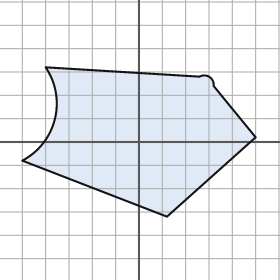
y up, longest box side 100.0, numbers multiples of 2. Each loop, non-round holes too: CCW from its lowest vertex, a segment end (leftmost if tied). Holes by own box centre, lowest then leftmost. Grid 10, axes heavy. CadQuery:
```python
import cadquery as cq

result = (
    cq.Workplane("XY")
    .moveTo(12.0, -32.0)
    .lineTo(50.0, 2.0)
    .lineTo(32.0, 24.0)
    .threePointArc((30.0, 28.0), (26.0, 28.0))
    .lineTo(-40.0, 32.0)
    .threePointArc((-36.0, 10.0), (-50.0, -8.0))
    .close()
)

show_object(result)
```